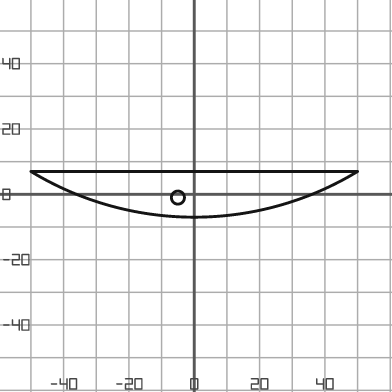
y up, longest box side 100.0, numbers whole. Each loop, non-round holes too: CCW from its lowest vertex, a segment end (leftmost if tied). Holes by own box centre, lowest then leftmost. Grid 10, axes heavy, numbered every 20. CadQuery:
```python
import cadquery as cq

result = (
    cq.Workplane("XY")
    .moveTo(-50.0, 7.0)
    .threePointArc((0.0, -7.0), (50.0, 7.0))
    .close()
    .moveTo(-5.0, -1.0)
    .circle(2.0)
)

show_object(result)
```